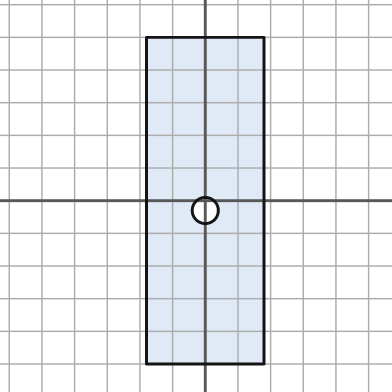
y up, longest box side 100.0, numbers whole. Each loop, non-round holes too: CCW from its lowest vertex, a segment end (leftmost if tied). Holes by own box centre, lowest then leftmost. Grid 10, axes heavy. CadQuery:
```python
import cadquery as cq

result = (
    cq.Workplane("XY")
    .moveTo(-18.0, -50.0)
    .lineTo(18.0, -50.0)
    .lineTo(18.0, 50.0)
    .lineTo(-18.0, 50.0)
    .close()
    .moveTo(0.0, -3.0)
    .circle(4.0)
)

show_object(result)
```